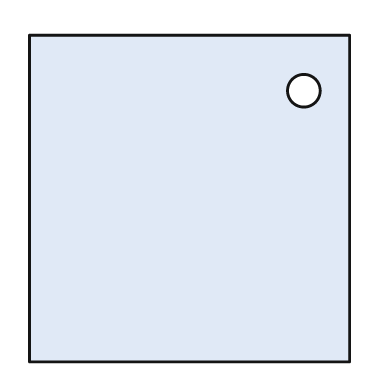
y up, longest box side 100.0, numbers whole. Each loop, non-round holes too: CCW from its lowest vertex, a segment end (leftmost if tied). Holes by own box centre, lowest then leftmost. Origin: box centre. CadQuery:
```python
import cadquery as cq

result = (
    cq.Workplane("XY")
    .moveTo(-49.0, -50.0)
    .lineTo(49.0, -50.0)
    .lineTo(49.0, 50.0)
    .lineTo(-49.0, 50.0)
    .close()
    .moveTo(35.0, 33.0)
    .circle(5.0)
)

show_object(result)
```